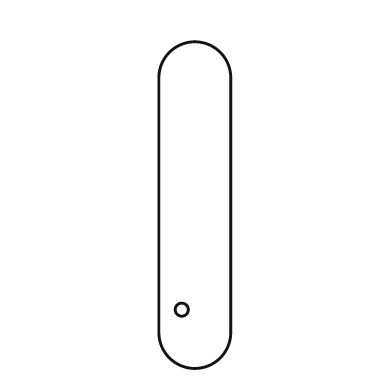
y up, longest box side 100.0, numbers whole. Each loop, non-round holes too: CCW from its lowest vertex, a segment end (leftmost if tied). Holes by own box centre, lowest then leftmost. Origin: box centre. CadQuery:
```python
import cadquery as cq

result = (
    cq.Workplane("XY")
    .moveTo(-11.0, -39.0)
    .threePointArc((0.0, -50.0), (11.0, -39.0))
    .lineTo(11.0, 39.0)
    .threePointArc((0.0, 50.0), (-11.0, 39.0))
    .close()
    .moveTo(-4.0, -32.0)
    .circle(2.0)
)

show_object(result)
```